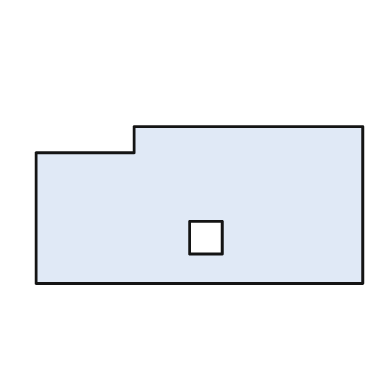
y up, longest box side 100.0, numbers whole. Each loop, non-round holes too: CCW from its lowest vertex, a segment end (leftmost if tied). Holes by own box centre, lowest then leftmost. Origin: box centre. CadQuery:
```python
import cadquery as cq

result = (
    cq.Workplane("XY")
    .moveTo(-50.0, -24.0)
    .lineTo(50.0, -24.0)
    .lineTo(50.0, 24.0)
    .lineTo(-20.0, 24.0)
    .lineTo(-20.0, 16.0)
    .lineTo(-50.0, 16.0)
    .close()
    .moveTo(-3.0, -15.0)
    .lineTo(7.0, -15.0)
    .lineTo(7.0, -5.0)
    .lineTo(-3.0, -5.0)
    .close()
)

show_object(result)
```